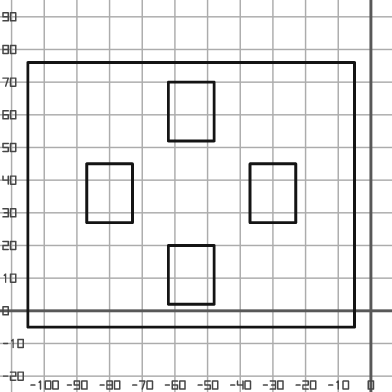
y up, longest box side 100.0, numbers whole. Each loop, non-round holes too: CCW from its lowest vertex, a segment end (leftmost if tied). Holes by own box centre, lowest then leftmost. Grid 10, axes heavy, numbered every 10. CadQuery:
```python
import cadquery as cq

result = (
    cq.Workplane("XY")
    .moveTo(-105.0, -5.0)
    .lineTo(-5.0, -5.0)
    .lineTo(-5.0, 76.0)
    .lineTo(-105.0, 76.0)
    .close()
    .moveTo(-62.0, 2.0)
    .lineTo(-48.0, 2.0)
    .lineTo(-48.0, 20.0)
    .lineTo(-62.0, 20.0)
    .close()
    .moveTo(-87.0, 27.0)
    .lineTo(-73.0, 27.0)
    .lineTo(-73.0, 45.0)
    .lineTo(-87.0, 45.0)
    .close()
    .moveTo(-37.0, 27.0)
    .lineTo(-23.0, 27.0)
    .lineTo(-23.0, 45.0)
    .lineTo(-37.0, 45.0)
    .close()
    .moveTo(-62.0, 52.0)
    .lineTo(-48.0, 52.0)
    .lineTo(-48.0, 70.0)
    .lineTo(-62.0, 70.0)
    .close()
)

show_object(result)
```